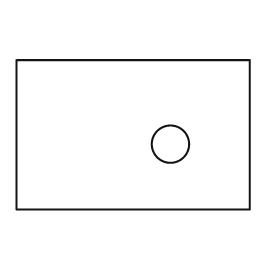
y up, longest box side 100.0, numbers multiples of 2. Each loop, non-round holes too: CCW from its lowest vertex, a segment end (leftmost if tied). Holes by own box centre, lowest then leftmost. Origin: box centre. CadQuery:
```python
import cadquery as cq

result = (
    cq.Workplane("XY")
    .moveTo(-50.0, -32.0)
    .lineTo(50.0, -32.0)
    .lineTo(50.0, 32.0)
    .lineTo(-50.0, 32.0)
    .close()
    .moveTo(16.0, -4.0)
    .circle(8.0)
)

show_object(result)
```